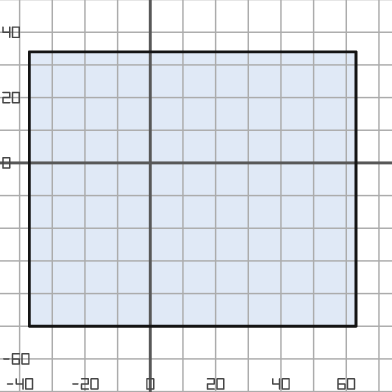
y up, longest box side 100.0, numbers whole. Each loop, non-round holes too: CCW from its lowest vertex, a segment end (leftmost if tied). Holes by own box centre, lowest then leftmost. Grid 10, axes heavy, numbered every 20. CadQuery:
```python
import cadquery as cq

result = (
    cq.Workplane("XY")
    .moveTo(-37.0, -50.0)
    .lineTo(63.0, -50.0)
    .lineTo(63.0, 34.0)
    .lineTo(-37.0, 34.0)
    .close()
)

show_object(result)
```